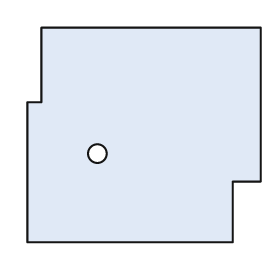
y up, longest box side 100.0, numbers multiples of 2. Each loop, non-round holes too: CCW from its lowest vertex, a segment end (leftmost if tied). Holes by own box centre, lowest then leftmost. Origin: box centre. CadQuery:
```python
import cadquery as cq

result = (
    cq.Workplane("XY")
    .moveTo(-50.0, -46.0)
    .lineTo(38.0, -46.0)
    .lineTo(38.0, -20.0)
    .lineTo(50.0, -20.0)
    .lineTo(50.0, 46.0)
    .lineTo(-44.0, 46.0)
    .lineTo(-44.0, 14.0)
    .lineTo(-50.0, 14.0)
    .close()
    .moveTo(-20.0, -8.0)
    .circle(4.0)
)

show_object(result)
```